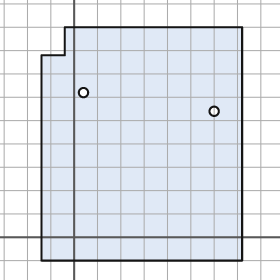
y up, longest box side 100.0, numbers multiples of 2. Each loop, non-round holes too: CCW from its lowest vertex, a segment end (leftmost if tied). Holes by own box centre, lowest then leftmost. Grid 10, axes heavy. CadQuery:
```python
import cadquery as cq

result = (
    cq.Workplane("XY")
    .moveTo(-14.0, -10.0)
    .lineTo(72.0, -10.0)
    .lineTo(72.0, 90.0)
    .lineTo(-4.0, 90.0)
    .lineTo(-4.0, 78.0)
    .lineTo(-14.0, 78.0)
    .close()
    .moveTo(60.0, 54.0)
    .circle(2.0)
    .moveTo(4.0, 62.0)
    .circle(2.0)
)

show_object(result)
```